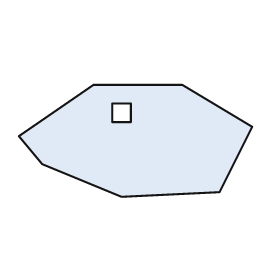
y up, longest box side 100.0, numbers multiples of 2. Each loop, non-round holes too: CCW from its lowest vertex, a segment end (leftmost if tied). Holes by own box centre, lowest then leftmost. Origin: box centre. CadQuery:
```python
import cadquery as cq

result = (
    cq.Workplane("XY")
    .moveTo(-6.0, -24.0)
    .lineTo(36.0, -22.0)
    .lineTo(50.0, 6.0)
    .lineTo(20.0, 24.0)
    .lineTo(-18.0, 24.0)
    .lineTo(-50.0, 2.0)
    .lineTo(-40.0, -10.0)
    .close()
    .moveTo(-10.0, 8.0)
    .lineTo(-2.0, 8.0)
    .lineTo(-2.0, 16.0)
    .lineTo(-10.0, 16.0)
    .close()
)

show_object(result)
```